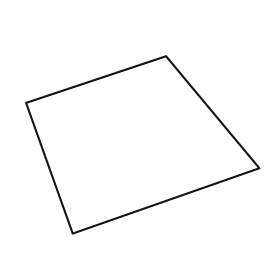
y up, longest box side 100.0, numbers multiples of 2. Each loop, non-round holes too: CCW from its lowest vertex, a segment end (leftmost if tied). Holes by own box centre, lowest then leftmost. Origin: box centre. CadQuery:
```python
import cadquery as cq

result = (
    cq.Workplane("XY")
    .moveTo(-30.0, -38.0)
    .lineTo(50.0, -10.0)
    .lineTo(10.0, 38.0)
    .lineTo(-50.0, 18.0)
    .close()
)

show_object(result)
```